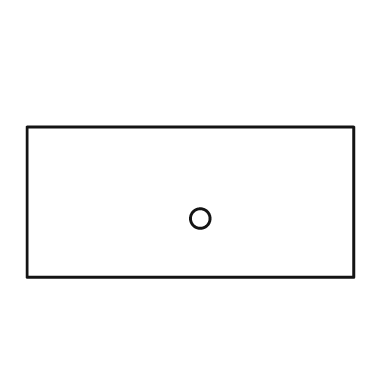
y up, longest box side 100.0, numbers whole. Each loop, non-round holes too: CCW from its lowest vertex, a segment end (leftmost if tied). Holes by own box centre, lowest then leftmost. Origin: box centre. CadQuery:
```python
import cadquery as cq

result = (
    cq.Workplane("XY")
    .moveTo(-50.0, -23.0)
    .lineTo(50.0, -23.0)
    .lineTo(50.0, 23.0)
    .lineTo(-50.0, 23.0)
    .close()
    .moveTo(3.0, -5.0)
    .circle(3.0)
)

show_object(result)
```